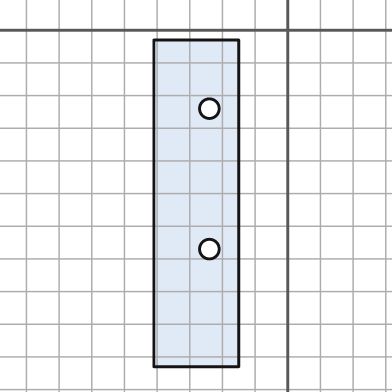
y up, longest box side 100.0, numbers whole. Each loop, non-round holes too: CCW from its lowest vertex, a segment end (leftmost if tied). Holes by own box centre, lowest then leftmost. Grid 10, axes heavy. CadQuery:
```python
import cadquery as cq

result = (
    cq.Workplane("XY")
    .moveTo(-41.0, -103.0)
    .lineTo(-15.0, -103.0)
    .lineTo(-15.0, -3.0)
    .lineTo(-41.0, -3.0)
    .close()
    .moveTo(-24.0, -67.0)
    .circle(3.0)
    .moveTo(-24.0, -24.0)
    .circle(3.0)
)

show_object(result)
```